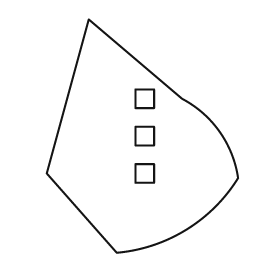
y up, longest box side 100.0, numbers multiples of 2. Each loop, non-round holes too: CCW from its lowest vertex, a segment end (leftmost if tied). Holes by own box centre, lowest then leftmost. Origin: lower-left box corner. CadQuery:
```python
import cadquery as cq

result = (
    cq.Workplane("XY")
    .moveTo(30.0, 0.0)
    .threePointArc((60.0, 10.0), (82.0, 32.0))
    .threePointArc((74.0, 52.0), (58.0, 66.0))
    .lineTo(18.0, 100.0)
    .lineTo(0.0, 34.0)
    .close()
    .moveTo(38.0, 30.0)
    .lineTo(46.0, 30.0)
    .lineTo(46.0, 38.0)
    .lineTo(38.0, 38.0)
    .close()
    .moveTo(38.0, 46.0)
    .lineTo(46.0, 46.0)
    .lineTo(46.0, 54.0)
    .lineTo(38.0, 54.0)
    .close()
    .moveTo(38.0, 62.0)
    .lineTo(46.0, 62.0)
    .lineTo(46.0, 70.0)
    .lineTo(38.0, 70.0)
    .close()
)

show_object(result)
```